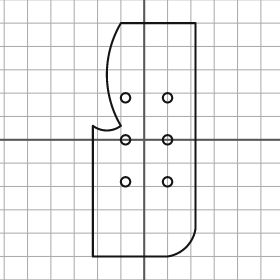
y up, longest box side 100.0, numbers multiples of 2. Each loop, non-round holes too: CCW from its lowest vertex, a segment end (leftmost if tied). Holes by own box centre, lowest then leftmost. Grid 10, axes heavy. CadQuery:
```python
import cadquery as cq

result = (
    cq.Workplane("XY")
    .moveTo(-22.0, -50.0)
    .lineTo(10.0, -50.0)
    .threePointArc((18.0, -46.0), (22.0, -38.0))
    .lineTo(22.0, 50.0)
    .lineTo(-10.0, 50.0)
    .threePointArc((-16.0, 28.0), (-10.0, 6.0))
    .threePointArc((-16.0, 4.0), (-22.0, 6.0))
    .close()
    .moveTo(-8.0, -18.0)
    .circle(2.0)
    .moveTo(10.0, -18.0)
    .circle(2.0)
    .moveTo(-8.0, 0.0)
    .circle(2.0)
    .moveTo(10.0, 0.0)
    .circle(2.0)
    .moveTo(-8.0, 18.0)
    .circle(2.0)
    .moveTo(10.0, 18.0)
    .circle(2.0)
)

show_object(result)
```